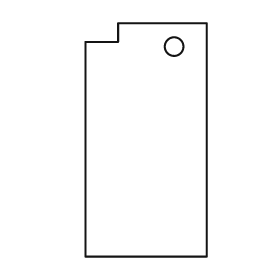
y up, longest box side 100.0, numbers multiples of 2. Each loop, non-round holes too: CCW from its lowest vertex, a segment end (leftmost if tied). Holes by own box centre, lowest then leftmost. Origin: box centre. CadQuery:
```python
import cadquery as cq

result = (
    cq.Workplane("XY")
    .moveTo(-26.0, -50.0)
    .lineTo(26.0, -50.0)
    .lineTo(26.0, 50.0)
    .lineTo(-12.0, 50.0)
    .lineTo(-12.0, 42.0)
    .lineTo(-26.0, 42.0)
    .close()
    .moveTo(12.0, 40.0)
    .circle(4.0)
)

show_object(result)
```